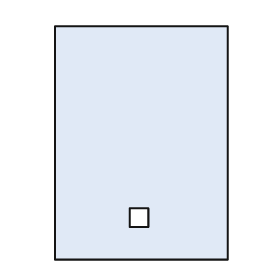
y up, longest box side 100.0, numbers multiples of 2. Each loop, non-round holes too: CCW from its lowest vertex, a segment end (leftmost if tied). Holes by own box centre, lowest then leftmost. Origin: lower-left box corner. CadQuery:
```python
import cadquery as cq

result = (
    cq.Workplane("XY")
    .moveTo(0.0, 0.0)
    .lineTo(74.0, 0.0)
    .lineTo(74.0, 100.0)
    .lineTo(0.0, 100.0)
    .close()
    .moveTo(32.0, 14.0)
    .lineTo(40.0, 14.0)
    .lineTo(40.0, 22.0)
    .lineTo(32.0, 22.0)
    .close()
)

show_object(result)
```